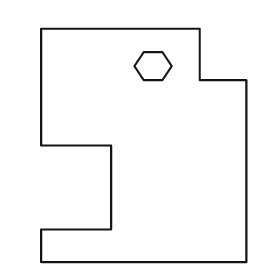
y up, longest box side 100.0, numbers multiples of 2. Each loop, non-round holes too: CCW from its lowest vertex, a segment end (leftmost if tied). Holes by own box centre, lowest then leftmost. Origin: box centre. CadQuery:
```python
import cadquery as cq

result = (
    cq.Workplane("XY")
    .moveTo(-44.0, -50.0)
    .lineTo(44.0, -50.0)
    .lineTo(44.0, 28.0)
    .lineTo(24.0, 28.0)
    .lineTo(24.0, 50.0)
    .lineTo(-44.0, 50.0)
    .lineTo(-44.0, 0.0)
    .lineTo(-14.0, 0.0)
    .lineTo(-14.0, -36.0)
    .lineTo(-44.0, -36.0)
    .close()
    .moveTo(0.0, 28.0)
    .lineTo(8.0, 28.0)
    .lineTo(12.0, 34.0)
    .lineTo(8.0, 40.0)
    .lineTo(0.0, 40.0)
    .lineTo(-4.0, 34.0)
    .close()
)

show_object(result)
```